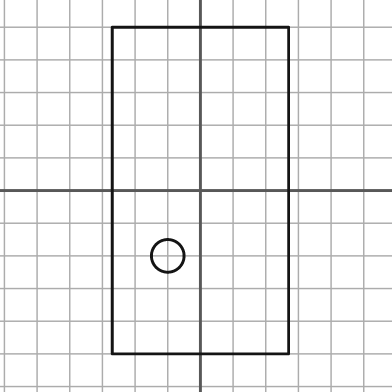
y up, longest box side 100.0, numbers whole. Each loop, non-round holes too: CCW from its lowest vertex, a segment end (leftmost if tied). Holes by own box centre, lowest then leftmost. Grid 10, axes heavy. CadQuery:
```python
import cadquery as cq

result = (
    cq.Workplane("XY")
    .moveTo(-27.0, -50.0)
    .lineTo(27.0, -50.0)
    .lineTo(27.0, 50.0)
    .lineTo(-27.0, 50.0)
    .close()
    .moveTo(-10.0, -20.0)
    .circle(5.0)
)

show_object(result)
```